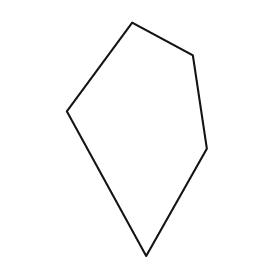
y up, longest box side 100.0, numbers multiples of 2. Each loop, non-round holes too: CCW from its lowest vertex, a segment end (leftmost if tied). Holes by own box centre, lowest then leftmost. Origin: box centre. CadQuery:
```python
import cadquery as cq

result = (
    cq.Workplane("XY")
    .moveTo(4.0, -50.0)
    .lineTo(30.0, -4.0)
    .lineTo(24.0, 36.0)
    .lineTo(-2.0, 50.0)
    .lineTo(-30.0, 12.0)
    .close()
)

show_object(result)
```